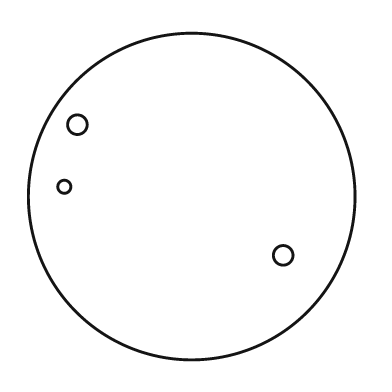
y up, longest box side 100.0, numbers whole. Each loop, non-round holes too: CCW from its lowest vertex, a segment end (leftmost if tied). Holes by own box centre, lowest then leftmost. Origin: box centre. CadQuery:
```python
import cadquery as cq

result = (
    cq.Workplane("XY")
    .moveTo(0.0, 0.0)
    .circle(50.0)
    .moveTo(28.0, -18.0)
    .circle(3.0)
    .moveTo(-39.0, 3.0)
    .circle(2.0)
    .moveTo(-35.0, 22.0)
    .circle(3.0)
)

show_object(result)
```